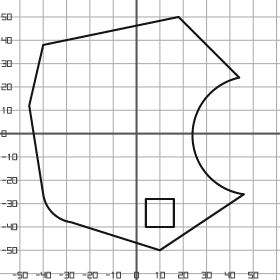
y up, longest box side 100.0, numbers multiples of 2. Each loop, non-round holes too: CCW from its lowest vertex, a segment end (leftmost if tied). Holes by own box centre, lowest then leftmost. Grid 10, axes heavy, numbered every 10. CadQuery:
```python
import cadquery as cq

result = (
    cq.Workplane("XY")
    .moveTo(10.0, -50.0)
    .lineTo(46.0, -26.0)
    .threePointArc((24.0, -2.0), (44.0, 24.0))
    .lineTo(18.0, 50.0)
    .lineTo(-40.0, 38.0)
    .lineTo(-46.0, 12.0)
    .lineTo(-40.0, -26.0)
    .threePointArc((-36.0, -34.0), (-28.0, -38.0))
    .close()
    .moveTo(4.0, -40.0)
    .lineTo(16.0, -40.0)
    .lineTo(16.0, -28.0)
    .lineTo(4.0, -28.0)
    .close()
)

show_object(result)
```